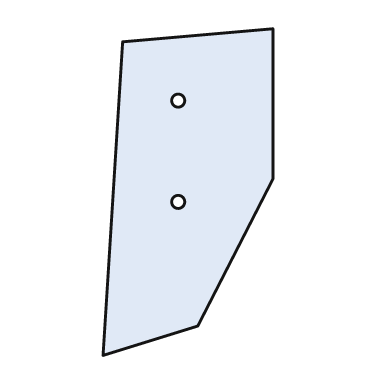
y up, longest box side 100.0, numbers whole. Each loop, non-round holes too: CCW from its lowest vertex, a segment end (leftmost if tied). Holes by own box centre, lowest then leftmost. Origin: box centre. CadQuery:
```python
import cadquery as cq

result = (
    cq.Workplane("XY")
    .moveTo(-26.0, -50.0)
    .lineTo(3.0, -41.0)
    .lineTo(26.0, 4.0)
    .lineTo(26.0, 50.0)
    .lineTo(-20.0, 46.0)
    .close()
    .moveTo(-3.0, -3.0)
    .circle(2.0)
    .moveTo(-3.0, 28.0)
    .circle(2.0)
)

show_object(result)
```